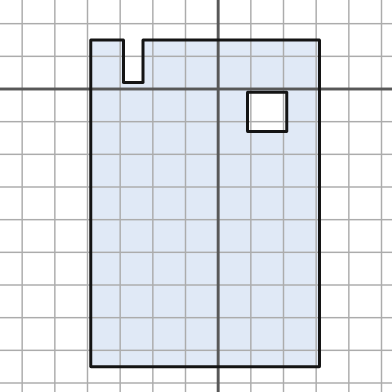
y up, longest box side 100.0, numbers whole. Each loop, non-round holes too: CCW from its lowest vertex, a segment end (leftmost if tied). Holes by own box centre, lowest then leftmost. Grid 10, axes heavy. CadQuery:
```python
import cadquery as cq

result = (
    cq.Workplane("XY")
    .moveTo(-39.0, -85.0)
    .lineTo(31.0, -85.0)
    .lineTo(31.0, 15.0)
    .lineTo(-23.0, 15.0)
    .lineTo(-23.0, 2.0)
    .lineTo(-29.0, 2.0)
    .lineTo(-29.0, 15.0)
    .lineTo(-39.0, 15.0)
    .close()
    .moveTo(9.0, -13.0)
    .lineTo(21.0, -13.0)
    .lineTo(21.0, -1.0)
    .lineTo(9.0, -1.0)
    .close()
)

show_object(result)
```